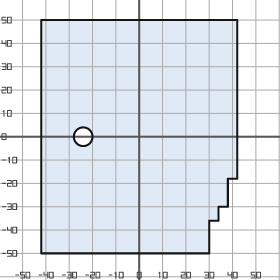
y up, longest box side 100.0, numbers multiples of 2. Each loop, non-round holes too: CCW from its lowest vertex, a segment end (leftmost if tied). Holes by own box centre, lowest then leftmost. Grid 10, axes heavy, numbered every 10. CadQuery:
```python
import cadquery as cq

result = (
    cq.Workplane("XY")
    .moveTo(-42.0, -50.0)
    .lineTo(30.0, -50.0)
    .lineTo(30.0, -36.0)
    .lineTo(34.0, -36.0)
    .lineTo(34.0, -30.0)
    .lineTo(38.0, -30.0)
    .lineTo(38.0, -18.0)
    .lineTo(42.0, -18.0)
    .lineTo(42.0, 50.0)
    .lineTo(-42.0, 50.0)
    .close()
    .moveTo(-24.0, 0.0)
    .circle(4.0)
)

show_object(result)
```